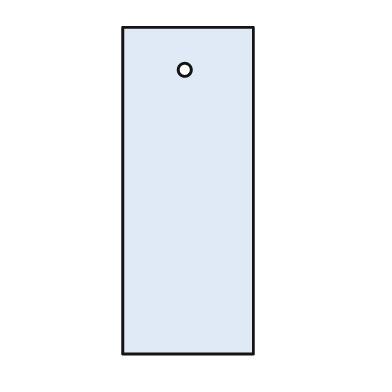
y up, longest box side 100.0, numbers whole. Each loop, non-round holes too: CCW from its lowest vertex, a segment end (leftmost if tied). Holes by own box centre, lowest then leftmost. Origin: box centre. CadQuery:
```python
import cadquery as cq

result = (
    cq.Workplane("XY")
    .moveTo(-20.0, -50.0)
    .lineTo(20.0, -50.0)
    .lineTo(20.0, 50.0)
    .lineTo(-20.0, 50.0)
    .close()
    .moveTo(-1.0, 37.0)
    .circle(2.0)
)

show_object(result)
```